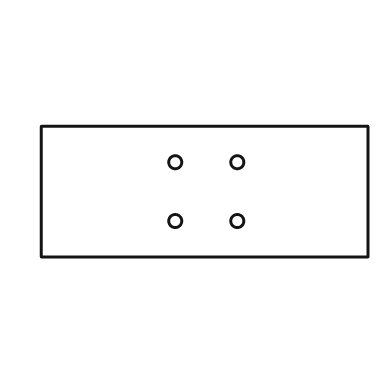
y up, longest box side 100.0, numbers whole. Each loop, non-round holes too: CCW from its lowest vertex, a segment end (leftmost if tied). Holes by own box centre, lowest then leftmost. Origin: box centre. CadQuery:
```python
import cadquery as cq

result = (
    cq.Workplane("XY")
    .moveTo(-50.0, -20.0)
    .lineTo(50.0, -20.0)
    .lineTo(50.0, 20.0)
    .lineTo(-50.0, 20.0)
    .close()
    .moveTo(-9.0, -9.0)
    .circle(2.0)
    .moveTo(10.0, -9.0)
    .circle(2.0)
    .moveTo(-9.0, 9.0)
    .circle(2.0)
    .moveTo(10.0, 9.0)
    .circle(2.0)
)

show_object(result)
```